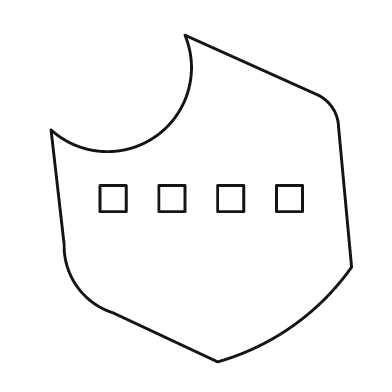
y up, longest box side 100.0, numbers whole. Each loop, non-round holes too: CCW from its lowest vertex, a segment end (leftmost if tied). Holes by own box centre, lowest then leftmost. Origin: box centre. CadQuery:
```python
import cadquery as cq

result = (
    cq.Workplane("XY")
    .moveTo(5.0, -50.0)
    .threePointArc((28.0, -39.0), (46.0, -21.0))
    .lineTo(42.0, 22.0)
    .threePointArc((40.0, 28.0), (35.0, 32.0))
    .lineTo(-5.0, 50.0)
    .threePointArc((-14.0, 19.0), (-46.0, 21.0))
    .lineTo(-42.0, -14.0)
    .threePointArc((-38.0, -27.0), (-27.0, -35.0))
    .close()
    .moveTo(-31.0, -4.0)
    .lineTo(-23.0, -4.0)
    .lineTo(-23.0, 4.0)
    .lineTo(-31.0, 4.0)
    .close()
    .moveTo(-13.0, -4.0)
    .lineTo(-5.0, -4.0)
    .lineTo(-5.0, 4.0)
    .lineTo(-13.0, 4.0)
    .close()
    .moveTo(5.0, -4.0)
    .lineTo(13.0, -4.0)
    .lineTo(13.0, 4.0)
    .lineTo(5.0, 4.0)
    .close()
    .moveTo(23.0, -4.0)
    .lineTo(31.0, -4.0)
    .lineTo(31.0, 4.0)
    .lineTo(23.0, 4.0)
    .close()
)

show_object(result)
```